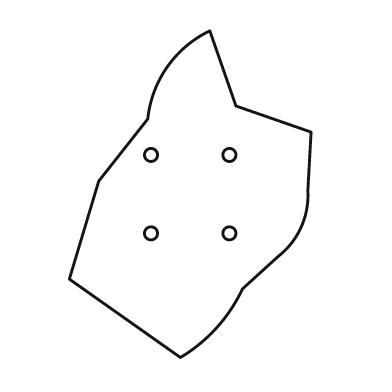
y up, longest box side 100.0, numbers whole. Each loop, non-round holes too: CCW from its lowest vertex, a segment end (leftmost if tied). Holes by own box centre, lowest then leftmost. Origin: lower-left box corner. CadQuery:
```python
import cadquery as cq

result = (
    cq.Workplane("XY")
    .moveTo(34.0, 0.0)
    .threePointArc((45.0, 9.0), (53.0, 21.0))
    .lineTo(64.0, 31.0)
    .threePointArc((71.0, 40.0), (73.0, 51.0))
    .lineTo(74.0, 69.0)
    .lineTo(51.0, 77.0)
    .lineTo(43.0, 100.0)
    .threePointArc((30.0, 89.0), (24.0, 73.0))
    .lineTo(9.0, 54.0)
    .lineTo(0.0, 24.0)
    .close()
    .moveTo(25.0, 38.0)
    .circle(2.0)
    .moveTo(49.0, 38.0)
    .circle(2.0)
    .moveTo(25.0, 62.0)
    .circle(2.0)
    .moveTo(49.0, 62.0)
    .circle(2.0)
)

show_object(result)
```